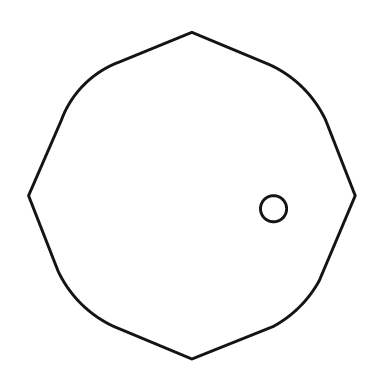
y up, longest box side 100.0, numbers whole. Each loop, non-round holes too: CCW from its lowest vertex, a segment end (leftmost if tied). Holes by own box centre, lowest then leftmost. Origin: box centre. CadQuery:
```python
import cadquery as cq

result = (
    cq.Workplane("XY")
    .moveTo(0.0, -50.0)
    .lineTo(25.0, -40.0)
    .threePointArc((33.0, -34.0), (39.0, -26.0))
    .lineTo(50.0, 0.0)
    .lineTo(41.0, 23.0)
    .threePointArc((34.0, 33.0), (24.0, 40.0))
    .lineTo(0.0, 50.0)
    .lineTo(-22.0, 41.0)
    .threePointArc((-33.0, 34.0), (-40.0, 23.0))
    .lineTo(-50.0, 0.0)
    .lineTo(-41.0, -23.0)
    .threePointArc((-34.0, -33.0), (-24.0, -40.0))
    .close()
    .moveTo(25.0, -4.0)
    .circle(4.0)
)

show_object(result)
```